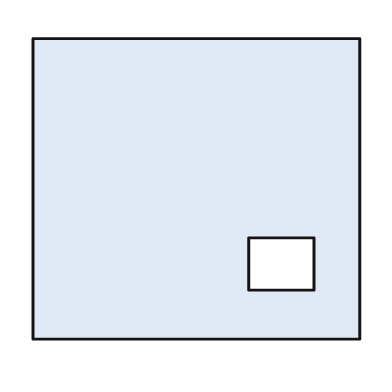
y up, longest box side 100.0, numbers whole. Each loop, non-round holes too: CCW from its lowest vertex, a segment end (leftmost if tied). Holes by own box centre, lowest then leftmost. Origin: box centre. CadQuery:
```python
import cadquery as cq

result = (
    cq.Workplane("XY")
    .moveTo(-50.0, -46.0)
    .lineTo(50.0, -46.0)
    .lineTo(50.0, 46.0)
    .lineTo(-50.0, 46.0)
    .close()
    .moveTo(16.0, -31.0)
    .lineTo(36.0, -31.0)
    .lineTo(36.0, -15.0)
    .lineTo(16.0, -15.0)
    .close()
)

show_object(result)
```